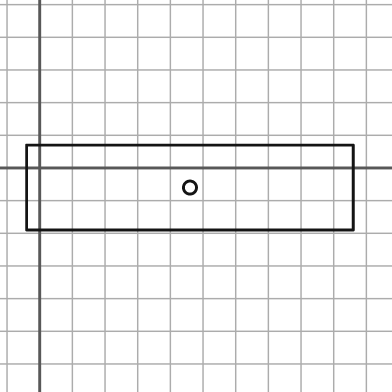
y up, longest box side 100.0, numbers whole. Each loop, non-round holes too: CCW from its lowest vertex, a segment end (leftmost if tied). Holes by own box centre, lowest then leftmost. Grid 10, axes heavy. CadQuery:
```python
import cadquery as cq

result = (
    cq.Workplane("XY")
    .moveTo(-4.0, -19.0)
    .lineTo(96.0, -19.0)
    .lineTo(96.0, 7.0)
    .lineTo(-4.0, 7.0)
    .close()
    .moveTo(46.0, -6.0)
    .circle(2.0)
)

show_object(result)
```